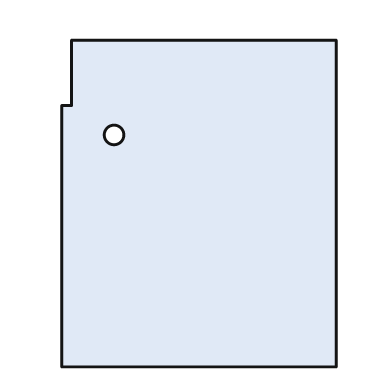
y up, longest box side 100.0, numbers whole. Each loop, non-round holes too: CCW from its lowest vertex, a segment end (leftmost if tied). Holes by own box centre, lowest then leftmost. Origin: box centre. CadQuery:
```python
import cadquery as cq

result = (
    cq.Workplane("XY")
    .moveTo(-42.0, -50.0)
    .lineTo(42.0, -50.0)
    .lineTo(42.0, 50.0)
    .lineTo(-39.0, 50.0)
    .lineTo(-39.0, 30.0)
    .lineTo(-42.0, 30.0)
    .close()
    .moveTo(-26.0, 21.0)
    .circle(3.0)
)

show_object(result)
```